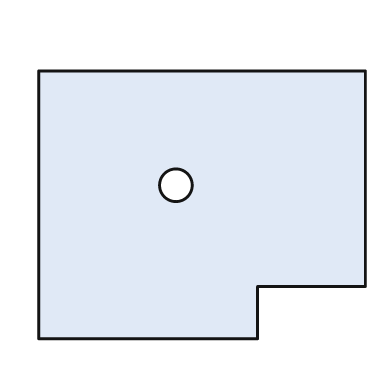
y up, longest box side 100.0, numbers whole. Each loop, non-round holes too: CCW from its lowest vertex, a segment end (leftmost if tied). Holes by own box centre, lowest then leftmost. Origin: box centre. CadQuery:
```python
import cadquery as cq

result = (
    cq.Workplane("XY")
    .moveTo(-50.0, -41.0)
    .lineTo(17.0, -41.0)
    .lineTo(17.0, -25.0)
    .lineTo(50.0, -25.0)
    .lineTo(50.0, 41.0)
    .lineTo(-50.0, 41.0)
    .close()
    .moveTo(-8.0, 6.0)
    .circle(5.0)
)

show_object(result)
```